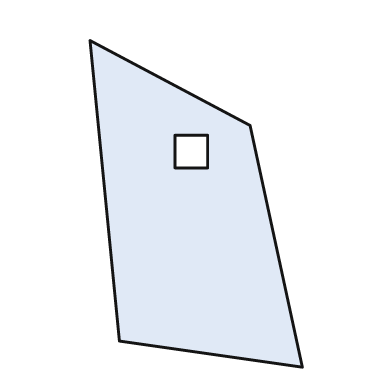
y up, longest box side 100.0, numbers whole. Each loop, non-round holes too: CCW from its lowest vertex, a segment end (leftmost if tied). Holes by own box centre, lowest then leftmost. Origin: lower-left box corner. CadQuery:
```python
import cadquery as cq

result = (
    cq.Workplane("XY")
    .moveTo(65.0, 0.0)
    .lineTo(49.0, 74.0)
    .lineTo(0.0, 100.0)
    .lineTo(9.0, 8.0)
    .close()
    .moveTo(26.0, 61.0)
    .lineTo(36.0, 61.0)
    .lineTo(36.0, 71.0)
    .lineTo(26.0, 71.0)
    .close()
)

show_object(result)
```